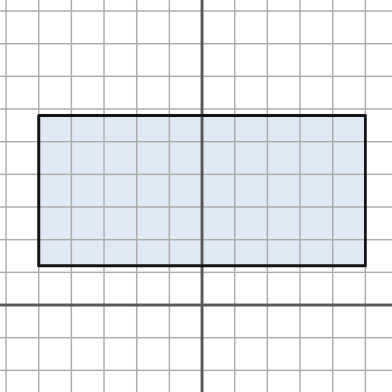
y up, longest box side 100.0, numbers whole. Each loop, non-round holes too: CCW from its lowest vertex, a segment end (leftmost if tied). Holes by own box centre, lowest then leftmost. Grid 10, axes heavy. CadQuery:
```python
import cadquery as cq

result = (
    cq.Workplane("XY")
    .moveTo(-50.0, 12.0)
    .lineTo(50.0, 12.0)
    .lineTo(50.0, 58.0)
    .lineTo(-50.0, 58.0)
    .close()
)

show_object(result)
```